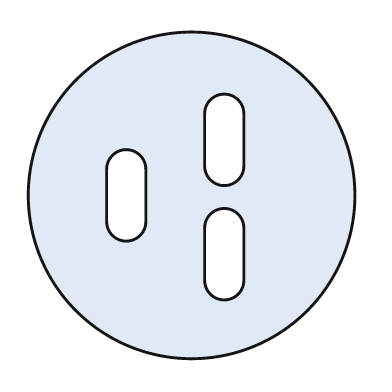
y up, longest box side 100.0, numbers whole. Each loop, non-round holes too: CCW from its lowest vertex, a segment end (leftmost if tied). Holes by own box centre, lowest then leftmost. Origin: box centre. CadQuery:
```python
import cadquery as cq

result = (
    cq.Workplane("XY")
    .moveTo(0.0, 0.0)
    .circle(50.0)
    .moveTo(4.0, -26.0)
    .threePointArc((10.0, -32.0), (16.0, -26.0))
    .lineTo(16.0, -10.0)
    .threePointArc((10.0, -4.0), (4.0, -10.0))
    .close()
    .moveTo(-26.0, -8.0)
    .threePointArc((-20.0, -14.0), (-14.0, -8.0))
    .lineTo(-14.0, 8.0)
    .threePointArc((-20.0, 14.0), (-26.0, 8.0))
    .close()
    .moveTo(4.0, 9.0)
    .threePointArc((10.0, 3.0), (16.0, 9.0))
    .lineTo(16.0, 25.0)
    .threePointArc((10.0, 31.0), (4.0, 25.0))
    .close()
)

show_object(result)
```